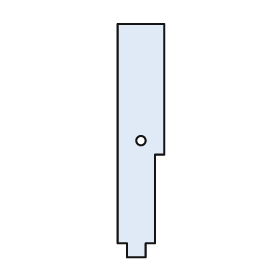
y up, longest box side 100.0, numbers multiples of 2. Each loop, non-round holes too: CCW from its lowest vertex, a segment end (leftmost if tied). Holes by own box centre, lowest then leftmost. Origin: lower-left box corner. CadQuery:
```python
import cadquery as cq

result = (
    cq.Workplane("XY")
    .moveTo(4.0, 0.0)
    .lineTo(12.0, 0.0)
    .lineTo(12.0, 6.0)
    .lineTo(16.0, 6.0)
    .lineTo(16.0, 44.0)
    .lineTo(20.0, 44.0)
    .lineTo(20.0, 100.0)
    .lineTo(0.0, 100.0)
    .lineTo(0.0, 6.0)
    .lineTo(4.0, 6.0)
    .close()
    .moveTo(10.0, 50.0)
    .circle(2.0)
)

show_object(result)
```